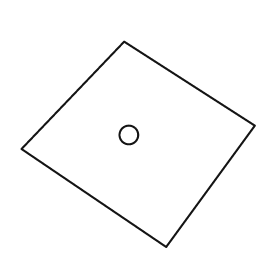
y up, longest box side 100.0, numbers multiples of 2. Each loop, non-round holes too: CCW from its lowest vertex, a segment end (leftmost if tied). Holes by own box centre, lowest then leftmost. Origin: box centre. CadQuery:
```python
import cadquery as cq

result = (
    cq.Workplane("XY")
    .moveTo(12.0, -44.0)
    .lineTo(50.0, 8.0)
    .lineTo(-6.0, 44.0)
    .lineTo(-50.0, -2.0)
    .close()
    .moveTo(-4.0, 4.0)
    .circle(4.0)
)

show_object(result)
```